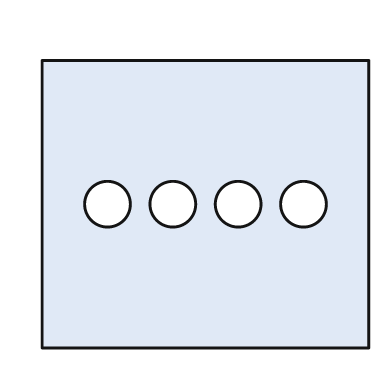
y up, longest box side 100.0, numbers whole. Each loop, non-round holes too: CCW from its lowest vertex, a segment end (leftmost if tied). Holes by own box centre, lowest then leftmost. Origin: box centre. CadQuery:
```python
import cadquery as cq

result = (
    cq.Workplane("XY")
    .moveTo(-50.0, -44.0)
    .lineTo(50.0, -44.0)
    .lineTo(50.0, 44.0)
    .lineTo(-50.0, 44.0)
    .close()
    .moveTo(-30.0, 0.0)
    .circle(7.0)
    .moveTo(-10.0, 0.0)
    .circle(7.0)
    .moveTo(10.0, 0.0)
    .circle(7.0)
    .moveTo(30.0, 0.0)
    .circle(7.0)
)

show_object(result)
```